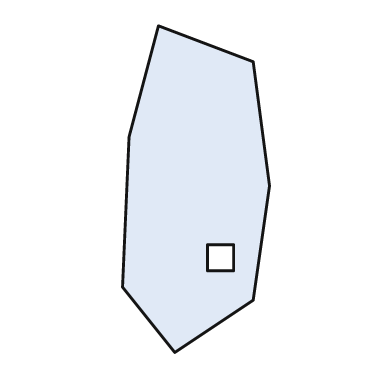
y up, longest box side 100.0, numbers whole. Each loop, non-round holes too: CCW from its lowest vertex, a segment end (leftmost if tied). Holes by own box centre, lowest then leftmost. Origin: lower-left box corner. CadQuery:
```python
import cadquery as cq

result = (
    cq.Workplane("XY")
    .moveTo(16.0, 0.0)
    .lineTo(40.0, 16.0)
    .lineTo(45.0, 51.0)
    .lineTo(40.0, 89.0)
    .lineTo(11.0, 100.0)
    .lineTo(2.0, 66.0)
    .lineTo(0.0, 20.0)
    .close()
    .moveTo(26.0, 25.0)
    .lineTo(34.0, 25.0)
    .lineTo(34.0, 33.0)
    .lineTo(26.0, 33.0)
    .close()
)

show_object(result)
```